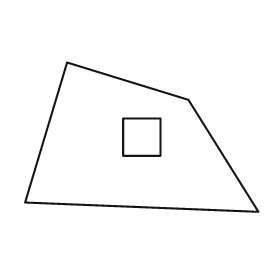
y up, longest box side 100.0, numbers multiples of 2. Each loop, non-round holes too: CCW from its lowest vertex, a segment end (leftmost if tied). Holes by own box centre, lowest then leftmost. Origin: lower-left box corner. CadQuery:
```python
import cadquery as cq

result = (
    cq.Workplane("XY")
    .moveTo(100.0, 0.0)
    .lineTo(70.0, 48.0)
    .lineTo(18.0, 64.0)
    .lineTo(0.0, 4.0)
    .close()
    .moveTo(42.0, 24.0)
    .lineTo(58.0, 24.0)
    .lineTo(58.0, 40.0)
    .lineTo(42.0, 40.0)
    .close()
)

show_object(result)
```